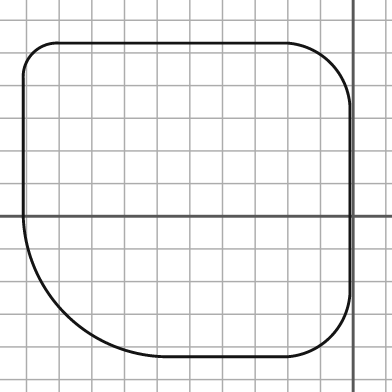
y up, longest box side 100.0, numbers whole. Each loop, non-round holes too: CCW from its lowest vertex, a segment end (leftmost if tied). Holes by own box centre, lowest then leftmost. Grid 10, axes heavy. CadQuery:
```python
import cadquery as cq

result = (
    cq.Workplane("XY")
    .moveTo(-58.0, -43.0)
    .lineTo(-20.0, -43.0)
    .threePointArc((-7.0, -37.0), (-1.0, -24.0))
    .lineTo(-1.0, 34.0)
    .threePointArc((-7.0, 47.0), (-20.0, 53.0))
    .lineTo(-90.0, 53.0)
    .threePointArc((-98.0, 50.0), (-101.0, 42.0))
    .lineTo(-101.0, 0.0)
    .threePointArc((-88.0, -30.0), (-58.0, -43.0))
    .close()
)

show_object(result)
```